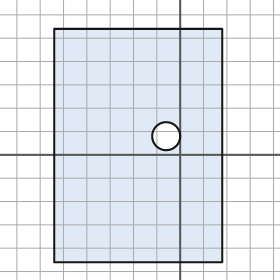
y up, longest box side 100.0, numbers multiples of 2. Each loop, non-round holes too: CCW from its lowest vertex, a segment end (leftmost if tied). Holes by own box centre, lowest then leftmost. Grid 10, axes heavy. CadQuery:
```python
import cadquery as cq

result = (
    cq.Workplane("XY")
    .moveTo(-54.0, -46.0)
    .lineTo(18.0, -46.0)
    .lineTo(18.0, 54.0)
    .lineTo(-54.0, 54.0)
    .close()
    .moveTo(-6.0, 8.0)
    .circle(6.0)
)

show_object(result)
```